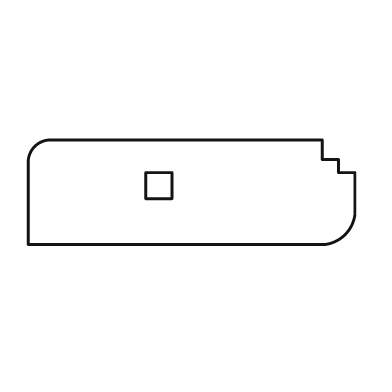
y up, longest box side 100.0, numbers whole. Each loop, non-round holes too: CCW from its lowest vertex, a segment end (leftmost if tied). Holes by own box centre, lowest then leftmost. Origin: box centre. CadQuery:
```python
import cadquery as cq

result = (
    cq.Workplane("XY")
    .moveTo(-50.0, -16.0)
    .lineTo(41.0, -16.0)
    .threePointArc((47.0, -13.0), (50.0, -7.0))
    .lineTo(50.0, 6.0)
    .lineTo(45.0, 6.0)
    .lineTo(45.0, 10.0)
    .lineTo(40.0, 10.0)
    .lineTo(40.0, 16.0)
    .lineTo(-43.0, 16.0)
    .threePointArc((-48.0, 14.0), (-50.0, 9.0))
    .close()
    .moveTo(-14.0, -2.0)
    .lineTo(-6.0, -2.0)
    .lineTo(-6.0, 6.0)
    .lineTo(-14.0, 6.0)
    .close()
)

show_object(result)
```